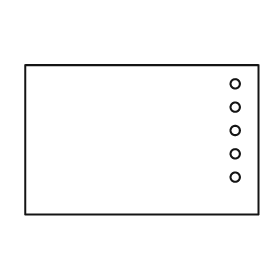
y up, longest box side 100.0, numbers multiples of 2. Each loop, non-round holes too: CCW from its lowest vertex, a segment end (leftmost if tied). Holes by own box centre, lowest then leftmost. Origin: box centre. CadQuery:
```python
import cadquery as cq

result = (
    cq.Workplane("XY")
    .moveTo(-50.0, -32.0)
    .lineTo(50.0, -32.0)
    .lineTo(50.0, 32.0)
    .lineTo(-50.0, 32.0)
    .close()
    .moveTo(40.0, -16.0)
    .circle(2.0)
    .moveTo(40.0, -6.0)
    .circle(2.0)
    .moveTo(40.0, 4.0)
    .circle(2.0)
    .moveTo(40.0, 14.0)
    .circle(2.0)
    .moveTo(40.0, 24.0)
    .circle(2.0)
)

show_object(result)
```